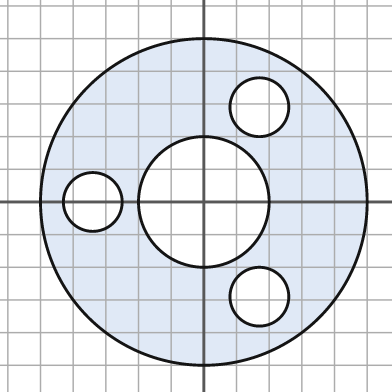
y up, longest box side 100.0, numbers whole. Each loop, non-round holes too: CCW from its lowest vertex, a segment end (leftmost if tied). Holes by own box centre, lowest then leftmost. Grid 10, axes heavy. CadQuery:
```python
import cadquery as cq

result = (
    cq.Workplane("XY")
    .moveTo(0.0, 0.0)
    .circle(50.0)
    .moveTo(17.0, -29.0)
    .circle(9.0)
    .moveTo(-34.0, 0.0)
    .circle(9.0)
    .moveTo(0.0, 0.0)
    .circle(20.0)
    .moveTo(17.0, 29.0)
    .circle(9.0)
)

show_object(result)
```